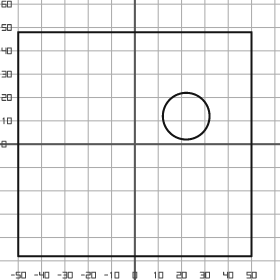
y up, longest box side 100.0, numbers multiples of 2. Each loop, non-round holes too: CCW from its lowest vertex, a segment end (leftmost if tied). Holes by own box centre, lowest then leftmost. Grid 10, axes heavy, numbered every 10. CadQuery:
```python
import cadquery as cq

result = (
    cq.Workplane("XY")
    .moveTo(-50.0, -48.0)
    .lineTo(50.0, -48.0)
    .lineTo(50.0, 48.0)
    .lineTo(-50.0, 48.0)
    .close()
    .moveTo(22.0, 12.0)
    .circle(10.0)
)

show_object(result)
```